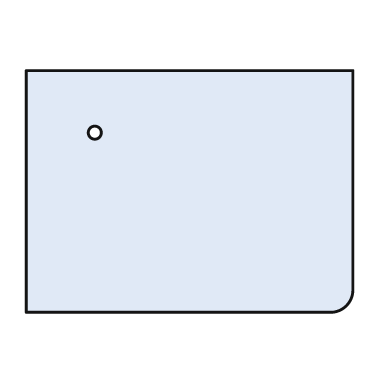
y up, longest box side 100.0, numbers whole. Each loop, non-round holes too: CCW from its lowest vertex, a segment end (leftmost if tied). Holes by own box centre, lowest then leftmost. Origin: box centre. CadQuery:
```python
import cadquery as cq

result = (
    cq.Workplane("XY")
    .moveTo(-50.0, -37.0)
    .lineTo(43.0, -37.0)
    .threePointArc((48.0, -35.0), (50.0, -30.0))
    .lineTo(50.0, 37.0)
    .lineTo(-50.0, 37.0)
    .close()
    .moveTo(-29.0, 18.0)
    .circle(2.0)
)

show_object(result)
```